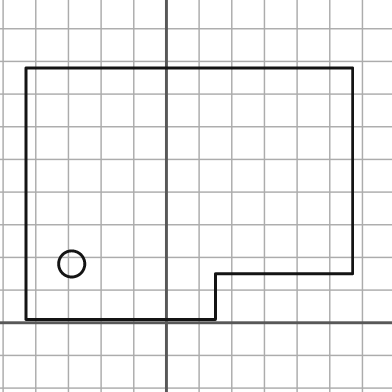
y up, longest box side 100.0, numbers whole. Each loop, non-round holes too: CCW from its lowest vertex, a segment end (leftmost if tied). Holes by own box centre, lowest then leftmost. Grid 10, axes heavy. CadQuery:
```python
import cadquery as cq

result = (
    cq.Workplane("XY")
    .moveTo(-43.0, 1.0)
    .lineTo(15.0, 1.0)
    .lineTo(15.0, 15.0)
    .lineTo(57.0, 15.0)
    .lineTo(57.0, 78.0)
    .lineTo(-43.0, 78.0)
    .close()
    .moveTo(-29.0, 18.0)
    .circle(4.0)
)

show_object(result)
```